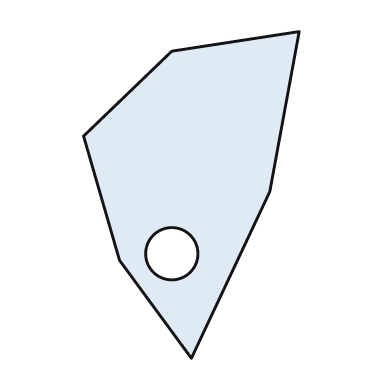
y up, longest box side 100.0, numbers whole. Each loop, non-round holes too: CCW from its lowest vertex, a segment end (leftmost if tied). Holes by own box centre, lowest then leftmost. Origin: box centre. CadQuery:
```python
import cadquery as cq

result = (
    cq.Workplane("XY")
    .moveTo(0.0, -50.0)
    .lineTo(24.0, 1.0)
    .lineTo(33.0, 50.0)
    .lineTo(-6.0, 44.0)
    .lineTo(-33.0, 18.0)
    .lineTo(-22.0, -20.0)
    .close()
    .moveTo(-6.0, -18.0)
    .circle(8.0)
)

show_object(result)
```